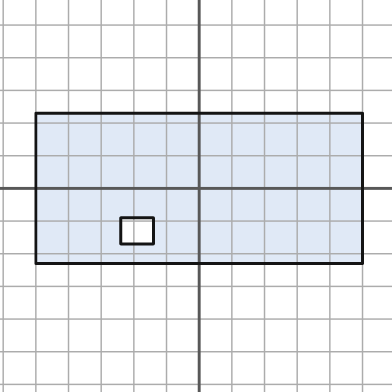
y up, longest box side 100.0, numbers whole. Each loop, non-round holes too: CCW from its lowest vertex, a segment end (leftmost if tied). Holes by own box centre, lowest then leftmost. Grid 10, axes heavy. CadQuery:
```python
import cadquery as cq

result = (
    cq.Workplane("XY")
    .moveTo(-50.0, -23.0)
    .lineTo(50.0, -23.0)
    .lineTo(50.0, 23.0)
    .lineTo(-50.0, 23.0)
    .close()
    .moveTo(-24.0, -17.0)
    .lineTo(-14.0, -17.0)
    .lineTo(-14.0, -9.0)
    .lineTo(-24.0, -9.0)
    .close()
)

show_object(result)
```